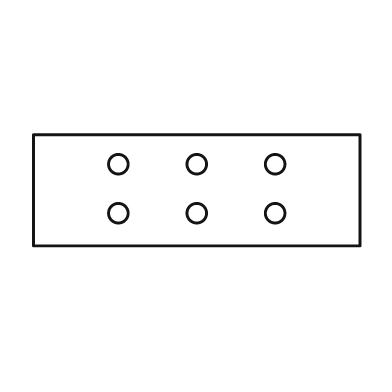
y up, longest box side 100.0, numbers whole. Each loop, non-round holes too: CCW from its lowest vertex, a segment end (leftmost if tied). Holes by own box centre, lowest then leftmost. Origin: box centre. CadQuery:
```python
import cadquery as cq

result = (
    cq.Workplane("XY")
    .moveTo(-50.0, -17.0)
    .lineTo(50.0, -17.0)
    .lineTo(50.0, 17.0)
    .lineTo(-50.0, 17.0)
    .close()
    .moveTo(-24.0, -7.0)
    .circle(3.0)
    .moveTo(0.0, -7.0)
    .circle(3.0)
    .moveTo(24.0, -7.0)
    .circle(3.0)
    .moveTo(-24.0, 8.0)
    .circle(3.0)
    .moveTo(0.0, 8.0)
    .circle(3.0)
    .moveTo(24.0, 8.0)
    .circle(3.0)
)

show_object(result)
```